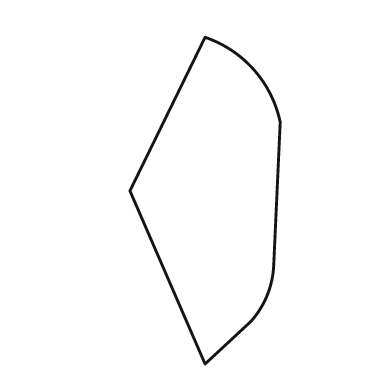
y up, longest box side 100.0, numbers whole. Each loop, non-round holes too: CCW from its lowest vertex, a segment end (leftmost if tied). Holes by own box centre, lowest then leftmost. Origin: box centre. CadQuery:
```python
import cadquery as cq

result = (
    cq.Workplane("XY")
    .moveTo(0.0, -50.0)
    .lineTo(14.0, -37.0)
    .threePointArc((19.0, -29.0), (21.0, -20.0))
    .lineTo(23.0, 24.0)
    .threePointArc((15.0, 40.0), (0.0, 50.0))
    .lineTo(-23.0, 3.0)
    .close()
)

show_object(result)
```